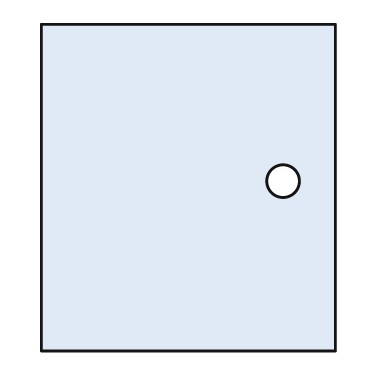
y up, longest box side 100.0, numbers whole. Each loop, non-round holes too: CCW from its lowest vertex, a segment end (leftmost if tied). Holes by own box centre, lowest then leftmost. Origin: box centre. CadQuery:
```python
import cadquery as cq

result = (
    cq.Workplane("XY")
    .moveTo(-45.0, -50.0)
    .lineTo(45.0, -50.0)
    .lineTo(45.0, 50.0)
    .lineTo(-45.0, 50.0)
    .close()
    .moveTo(29.0, 2.0)
    .circle(5.0)
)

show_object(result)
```